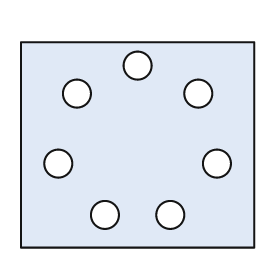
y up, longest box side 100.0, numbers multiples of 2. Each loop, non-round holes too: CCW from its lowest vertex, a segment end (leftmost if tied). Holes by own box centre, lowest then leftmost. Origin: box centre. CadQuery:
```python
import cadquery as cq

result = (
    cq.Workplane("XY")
    .moveTo(-50.0, -44.0)
    .lineTo(50.0, -44.0)
    .lineTo(50.0, 44.0)
    .lineTo(-50.0, 44.0)
    .close()
    .moveTo(-14.0, -30.0)
    .circle(6.0)
    .moveTo(14.0, -30.0)
    .circle(6.0)
    .moveTo(-34.0, -8.0)
    .circle(6.0)
    .moveTo(34.0, -8.0)
    .circle(6.0)
    .moveTo(-26.0, 22.0)
    .circle(6.0)
    .moveTo(26.0, 22.0)
    .circle(6.0)
    .moveTo(0.0, 34.0)
    .circle(6.0)
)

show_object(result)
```